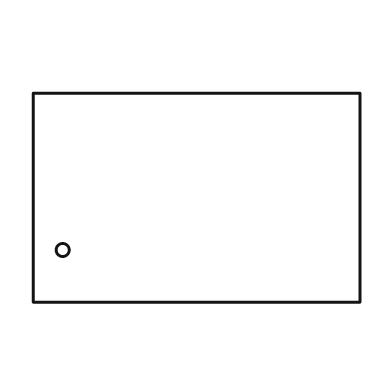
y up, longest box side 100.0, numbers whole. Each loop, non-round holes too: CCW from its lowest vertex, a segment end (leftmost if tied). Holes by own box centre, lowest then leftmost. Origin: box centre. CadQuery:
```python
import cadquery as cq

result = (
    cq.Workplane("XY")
    .moveTo(-50.0, -32.0)
    .lineTo(50.0, -32.0)
    .lineTo(50.0, 32.0)
    .lineTo(-50.0, 32.0)
    .close()
    .moveTo(-41.0, -16.0)
    .circle(2.0)
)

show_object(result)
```